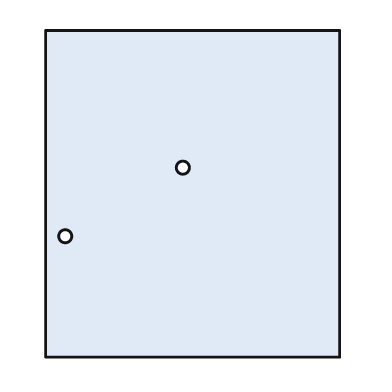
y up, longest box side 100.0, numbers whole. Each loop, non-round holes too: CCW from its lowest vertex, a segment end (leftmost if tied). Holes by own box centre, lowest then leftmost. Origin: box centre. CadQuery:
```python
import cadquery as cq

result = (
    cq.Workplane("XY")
    .moveTo(-45.0, -50.0)
    .lineTo(45.0, -50.0)
    .lineTo(45.0, 50.0)
    .lineTo(-45.0, 50.0)
    .close()
    .moveTo(-39.0, -13.0)
    .circle(2.0)
    .moveTo(-3.0, 8.0)
    .circle(2.0)
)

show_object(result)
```